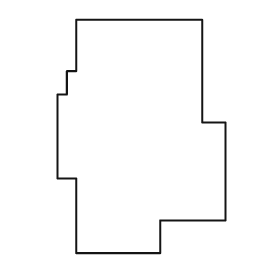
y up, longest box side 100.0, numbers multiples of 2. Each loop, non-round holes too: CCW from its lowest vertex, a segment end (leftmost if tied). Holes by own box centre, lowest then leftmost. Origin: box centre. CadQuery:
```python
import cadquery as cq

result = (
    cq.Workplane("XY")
    .moveTo(-28.0, -50.0)
    .lineTo(8.0, -50.0)
    .lineTo(8.0, -36.0)
    .lineTo(36.0, -36.0)
    .lineTo(36.0, 6.0)
    .lineTo(26.0, 6.0)
    .lineTo(26.0, 50.0)
    .lineTo(-28.0, 50.0)
    .lineTo(-28.0, 28.0)
    .lineTo(-32.0, 28.0)
    .lineTo(-32.0, 18.0)
    .lineTo(-36.0, 18.0)
    .lineTo(-36.0, -18.0)
    .lineTo(-28.0, -18.0)
    .close()
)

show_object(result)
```